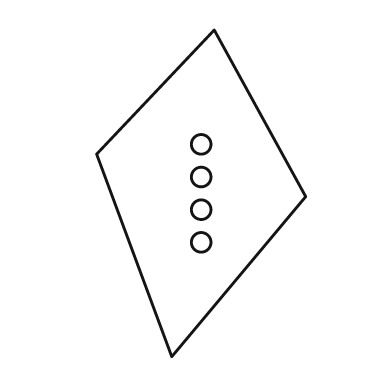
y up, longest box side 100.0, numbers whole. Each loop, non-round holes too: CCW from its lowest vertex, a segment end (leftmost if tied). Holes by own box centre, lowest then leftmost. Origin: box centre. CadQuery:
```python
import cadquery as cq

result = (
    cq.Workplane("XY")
    .moveTo(-9.0, -50.0)
    .lineTo(32.0, -1.0)
    .lineTo(4.0, 50.0)
    .lineTo(-32.0, 12.0)
    .close()
    .moveTo(0.0, -15.0)
    .circle(3.0)
    .moveTo(0.0, -5.0)
    .circle(3.0)
    .moveTo(0.0, 5.0)
    .circle(3.0)
    .moveTo(0.0, 15.0)
    .circle(3.0)
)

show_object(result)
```